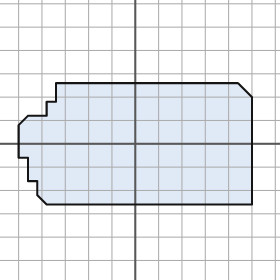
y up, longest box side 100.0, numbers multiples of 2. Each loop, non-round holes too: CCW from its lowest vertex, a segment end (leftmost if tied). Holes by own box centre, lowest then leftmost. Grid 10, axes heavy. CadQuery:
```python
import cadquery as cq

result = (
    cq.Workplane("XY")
    .moveTo(-38.0, -26.0)
    .lineTo(50.0, -26.0)
    .lineTo(50.0, 20.0)
    .lineTo(44.0, 26.0)
    .lineTo(-34.0, 26.0)
    .lineTo(-34.0, 18.0)
    .lineTo(-38.0, 18.0)
    .lineTo(-38.0, 12.0)
    .lineTo(-46.0, 12.0)
    .lineTo(-50.0, 8.0)
    .lineTo(-50.0, -6.0)
    .lineTo(-46.0, -6.0)
    .lineTo(-46.0, -16.0)
    .lineTo(-42.0, -16.0)
    .lineTo(-42.0, -22.0)
    .close()
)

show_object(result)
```